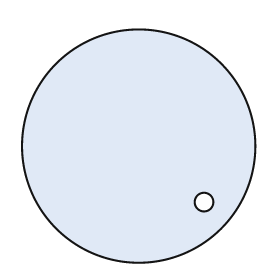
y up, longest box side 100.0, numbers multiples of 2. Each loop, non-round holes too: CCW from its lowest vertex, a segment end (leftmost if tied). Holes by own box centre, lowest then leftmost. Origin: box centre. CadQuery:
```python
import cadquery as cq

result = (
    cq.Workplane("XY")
    .moveTo(0.0, 0.0)
    .circle(50.0)
    .moveTo(28.0, -24.0)
    .circle(4.0)
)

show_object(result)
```